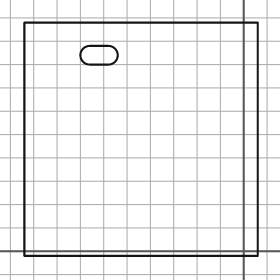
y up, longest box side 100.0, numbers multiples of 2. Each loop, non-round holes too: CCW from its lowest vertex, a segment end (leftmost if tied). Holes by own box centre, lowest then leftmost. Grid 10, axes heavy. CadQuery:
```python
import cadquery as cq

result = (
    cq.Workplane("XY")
    .moveTo(-94.0, -2.0)
    .lineTo(6.0, -2.0)
    .lineTo(6.0, 98.0)
    .lineTo(-94.0, 98.0)
    .close()
    .moveTo(-66.0, 80.0)
    .lineTo(-58.0, 80.0)
    .threePointArc((-54.0, 84.0), (-58.0, 88.0))
    .lineTo(-66.0, 88.0)
    .threePointArc((-70.0, 84.0), (-66.0, 80.0))
    .close()
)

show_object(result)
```